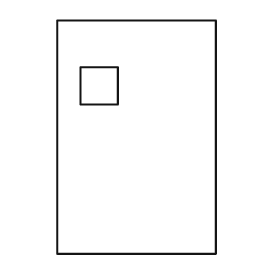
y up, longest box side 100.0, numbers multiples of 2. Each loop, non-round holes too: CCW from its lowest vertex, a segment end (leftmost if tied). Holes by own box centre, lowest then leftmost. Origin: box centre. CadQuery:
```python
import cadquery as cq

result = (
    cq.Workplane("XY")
    .moveTo(-34.0, -50.0)
    .lineTo(34.0, -50.0)
    .lineTo(34.0, 50.0)
    .lineTo(-34.0, 50.0)
    .close()
    .moveTo(-24.0, 14.0)
    .lineTo(-8.0, 14.0)
    .lineTo(-8.0, 30.0)
    .lineTo(-24.0, 30.0)
    .close()
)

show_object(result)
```